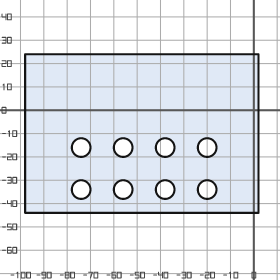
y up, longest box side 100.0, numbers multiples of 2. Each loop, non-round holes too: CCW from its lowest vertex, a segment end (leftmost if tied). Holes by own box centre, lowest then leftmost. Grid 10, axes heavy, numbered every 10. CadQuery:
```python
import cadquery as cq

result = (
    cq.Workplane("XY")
    .moveTo(-98.0, -44.0)
    .lineTo(2.0, -44.0)
    .lineTo(2.0, 24.0)
    .lineTo(-98.0, 24.0)
    .close()
    .moveTo(-74.0, -34.0)
    .circle(4.0)
    .moveTo(-56.0, -34.0)
    .circle(4.0)
    .moveTo(-38.0, -34.0)
    .circle(4.0)
    .moveTo(-20.0, -34.0)
    .circle(4.0)
    .moveTo(-74.0, -16.0)
    .circle(4.0)
    .moveTo(-56.0, -16.0)
    .circle(4.0)
    .moveTo(-38.0, -16.0)
    .circle(4.0)
    .moveTo(-20.0, -16.0)
    .circle(4.0)
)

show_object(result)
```